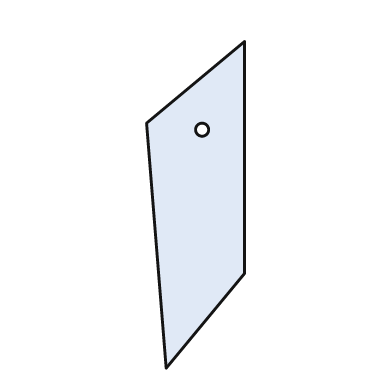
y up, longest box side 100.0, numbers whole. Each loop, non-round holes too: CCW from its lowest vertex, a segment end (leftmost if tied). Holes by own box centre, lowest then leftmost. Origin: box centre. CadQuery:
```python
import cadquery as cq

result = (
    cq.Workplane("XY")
    .moveTo(-9.0, -50.0)
    .lineTo(15.0, -21.0)
    .lineTo(15.0, 50.0)
    .lineTo(-15.0, 25.0)
    .close()
    .moveTo(2.0, 23.0)
    .circle(2.0)
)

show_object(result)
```